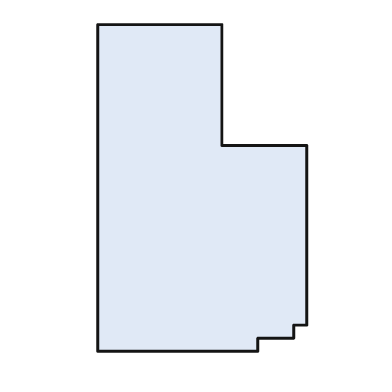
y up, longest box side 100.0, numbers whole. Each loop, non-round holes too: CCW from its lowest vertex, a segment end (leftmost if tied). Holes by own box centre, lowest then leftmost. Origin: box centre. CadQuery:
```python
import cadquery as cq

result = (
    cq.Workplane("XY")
    .moveTo(-32.0, -50.0)
    .lineTo(17.0, -50.0)
    .lineTo(17.0, -46.0)
    .lineTo(28.0, -46.0)
    .lineTo(28.0, -42.0)
    .lineTo(32.0, -42.0)
    .lineTo(32.0, 13.0)
    .lineTo(6.0, 13.0)
    .lineTo(6.0, 50.0)
    .lineTo(-32.0, 50.0)
    .close()
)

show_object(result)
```